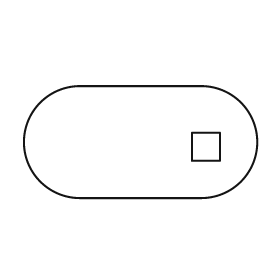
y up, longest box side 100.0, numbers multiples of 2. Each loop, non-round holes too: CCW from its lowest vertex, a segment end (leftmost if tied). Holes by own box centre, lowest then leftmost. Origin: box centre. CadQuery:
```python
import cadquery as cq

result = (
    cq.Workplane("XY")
    .moveTo(-26.0, -24.0)
    .lineTo(26.0, -24.0)
    .threePointArc((50.0, 0.0), (26.0, 24.0))
    .lineTo(-26.0, 24.0)
    .threePointArc((-50.0, 0.0), (-26.0, -24.0))
    .close()
    .moveTo(22.0, -8.0)
    .lineTo(34.0, -8.0)
    .lineTo(34.0, 4.0)
    .lineTo(22.0, 4.0)
    .close()
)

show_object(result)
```